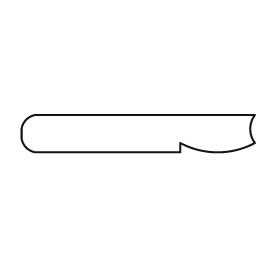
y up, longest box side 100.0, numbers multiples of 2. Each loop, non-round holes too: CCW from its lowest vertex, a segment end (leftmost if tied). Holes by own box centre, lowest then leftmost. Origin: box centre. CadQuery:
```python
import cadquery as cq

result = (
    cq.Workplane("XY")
    .moveTo(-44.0, -8.0)
    .lineTo(18.0, -8.0)
    .lineTo(18.0, -4.0)
    .threePointArc((34.0, -8.0), (50.0, -4.0))
    .threePointArc((48.0, 2.0), (50.0, 8.0))
    .lineTo(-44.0, 8.0)
    .threePointArc((-48.0, 6.0), (-50.0, 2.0))
    .lineTo(-50.0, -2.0)
    .threePointArc((-48.0, -6.0), (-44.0, -8.0))
    .close()
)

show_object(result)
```